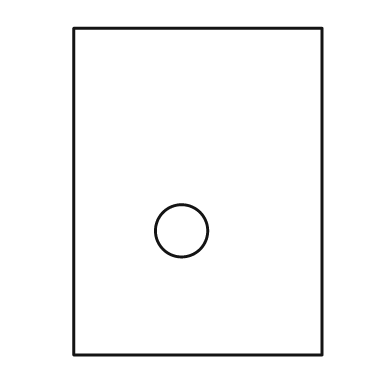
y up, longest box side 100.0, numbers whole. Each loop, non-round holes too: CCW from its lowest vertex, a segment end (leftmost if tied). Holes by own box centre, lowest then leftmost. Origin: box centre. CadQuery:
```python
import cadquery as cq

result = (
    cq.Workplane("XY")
    .moveTo(-38.0, -50.0)
    .lineTo(38.0, -50.0)
    .lineTo(38.0, 50.0)
    .lineTo(-38.0, 50.0)
    .close()
    .moveTo(-5.0, -12.0)
    .circle(8.0)
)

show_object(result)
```